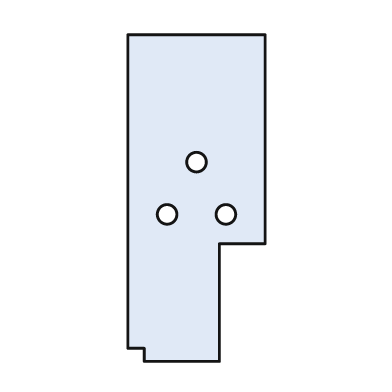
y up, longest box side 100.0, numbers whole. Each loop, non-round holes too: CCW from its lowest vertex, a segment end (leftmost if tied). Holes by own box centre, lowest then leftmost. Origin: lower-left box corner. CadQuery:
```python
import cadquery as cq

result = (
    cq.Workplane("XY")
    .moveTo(5.0, 0.0)
    .lineTo(28.0, 0.0)
    .lineTo(28.0, 36.0)
    .lineTo(42.0, 36.0)
    .lineTo(42.0, 100.0)
    .lineTo(0.0, 100.0)
    .lineTo(0.0, 4.0)
    .lineTo(5.0, 4.0)
    .close()
    .moveTo(12.0, 45.0)
    .circle(3.0)
    .moveTo(30.0, 45.0)
    .circle(3.0)
    .moveTo(21.0, 61.0)
    .circle(3.0)
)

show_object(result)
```